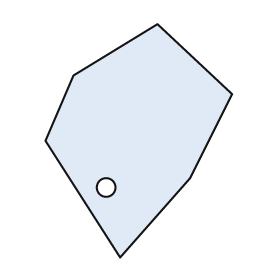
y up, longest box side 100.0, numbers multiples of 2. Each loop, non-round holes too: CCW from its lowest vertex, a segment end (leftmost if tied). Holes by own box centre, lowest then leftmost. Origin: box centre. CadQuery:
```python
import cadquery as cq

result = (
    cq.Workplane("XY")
    .moveTo(-8.0, -50.0)
    .lineTo(22.0, -16.0)
    .lineTo(40.0, 20.0)
    .lineTo(8.0, 50.0)
    .lineTo(-28.0, 28.0)
    .lineTo(-40.0, 0.0)
    .close()
    .moveTo(-14.0, -20.0)
    .circle(4.0)
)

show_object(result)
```